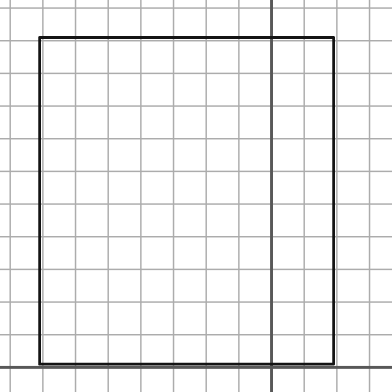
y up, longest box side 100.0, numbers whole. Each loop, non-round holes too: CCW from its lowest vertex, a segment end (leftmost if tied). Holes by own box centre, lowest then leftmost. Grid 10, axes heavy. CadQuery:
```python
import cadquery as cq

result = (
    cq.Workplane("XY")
    .moveTo(-71.0, 1.0)
    .lineTo(19.0, 1.0)
    .lineTo(19.0, 101.0)
    .lineTo(-71.0, 101.0)
    .close()
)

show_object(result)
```